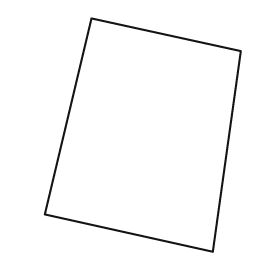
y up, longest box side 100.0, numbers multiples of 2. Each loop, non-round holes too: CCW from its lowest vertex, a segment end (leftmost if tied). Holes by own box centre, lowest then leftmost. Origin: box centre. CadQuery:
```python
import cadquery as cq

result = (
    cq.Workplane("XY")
    .moveTo(30.0, -50.0)
    .lineTo(42.0, 36.0)
    .lineTo(-22.0, 50.0)
    .lineTo(-42.0, -34.0)
    .close()
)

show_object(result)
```